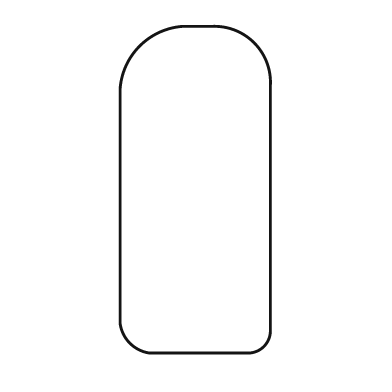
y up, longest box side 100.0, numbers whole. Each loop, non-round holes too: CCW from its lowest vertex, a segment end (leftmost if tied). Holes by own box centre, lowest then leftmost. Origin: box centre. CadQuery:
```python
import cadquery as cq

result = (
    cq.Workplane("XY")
    .moveTo(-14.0, -50.0)
    .lineTo(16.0, -50.0)
    .threePointArc((21.0, -48.0), (23.0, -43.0))
    .lineTo(23.0, 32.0)
    .threePointArc((18.0, 45.0), (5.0, 50.0))
    .lineTo(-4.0, 50.0)
    .threePointArc((-17.0, 44.0), (-23.0, 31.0))
    .lineTo(-23.0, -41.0)
    .threePointArc((-20.0, -47.0), (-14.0, -50.0))
    .close()
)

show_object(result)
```